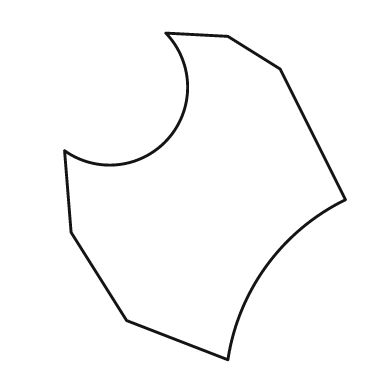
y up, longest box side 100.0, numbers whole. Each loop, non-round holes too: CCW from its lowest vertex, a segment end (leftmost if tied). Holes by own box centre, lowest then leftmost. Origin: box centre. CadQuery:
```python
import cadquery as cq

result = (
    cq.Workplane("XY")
    .moveTo(7.0, -50.0)
    .threePointArc((19.0, -21.0), (43.0, -1.0))
    .lineTo(23.0, 39.0)
    .lineTo(7.0, 49.0)
    .lineTo(-12.0, 50.0)
    .threePointArc((-11.0, 18.0), (-43.0, 14.0))
    .lineTo(-41.0, -11.0)
    .lineTo(-24.0, -38.0)
    .close()
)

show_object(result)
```